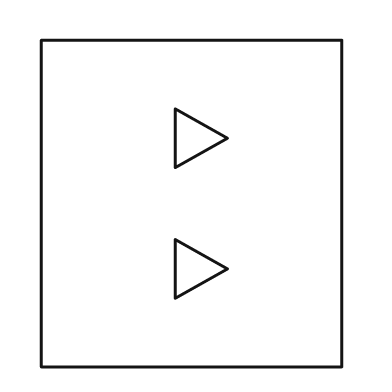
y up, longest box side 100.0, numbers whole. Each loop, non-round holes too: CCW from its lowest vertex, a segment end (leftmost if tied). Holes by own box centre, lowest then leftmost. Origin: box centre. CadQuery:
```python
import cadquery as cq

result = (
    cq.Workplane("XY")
    .moveTo(-46.0, -50.0)
    .lineTo(46.0, -50.0)
    .lineTo(46.0, 50.0)
    .lineTo(-46.0, 50.0)
    .close()
    .moveTo(-5.0, -29.0)
    .lineTo(11.0, -20.0)
    .lineTo(-5.0, -11.0)
    .close()
    .moveTo(-5.0, 11.0)
    .lineTo(11.0, 20.0)
    .lineTo(-5.0, 29.0)
    .close()
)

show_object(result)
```